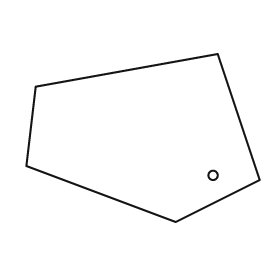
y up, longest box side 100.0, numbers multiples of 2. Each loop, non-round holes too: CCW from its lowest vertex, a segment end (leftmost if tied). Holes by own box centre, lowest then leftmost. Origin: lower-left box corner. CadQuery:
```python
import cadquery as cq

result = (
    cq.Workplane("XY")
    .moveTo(64.0, 0.0)
    .lineTo(100.0, 18.0)
    .lineTo(82.0, 72.0)
    .lineTo(4.0, 58.0)
    .lineTo(0.0, 24.0)
    .close()
    .moveTo(80.0, 20.0)
    .circle(2.0)
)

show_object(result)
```